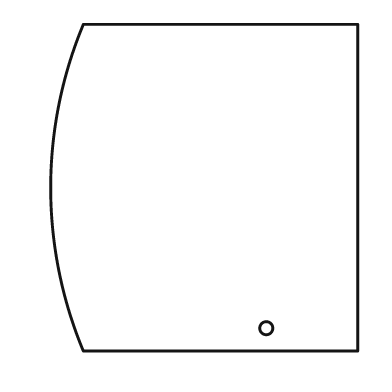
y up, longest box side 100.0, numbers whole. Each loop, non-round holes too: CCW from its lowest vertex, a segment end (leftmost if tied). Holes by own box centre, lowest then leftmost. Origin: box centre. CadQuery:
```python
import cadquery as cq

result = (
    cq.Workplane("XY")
    .moveTo(-37.0, -50.0)
    .lineTo(47.0, -50.0)
    .lineTo(47.0, 50.0)
    .lineTo(-37.0, 50.0)
    .threePointArc((-47.0, 0.0), (-37.0, -50.0))
    .close()
    .moveTo(19.0, -43.0)
    .circle(2.0)
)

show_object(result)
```